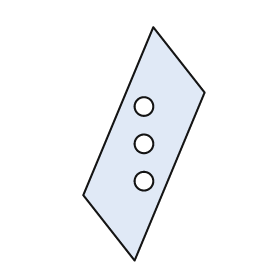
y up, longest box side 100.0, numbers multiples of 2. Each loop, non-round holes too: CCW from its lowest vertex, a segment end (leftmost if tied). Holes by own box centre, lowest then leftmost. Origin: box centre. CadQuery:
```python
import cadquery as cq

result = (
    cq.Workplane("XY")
    .moveTo(-4.0, -50.0)
    .lineTo(26.0, 22.0)
    .lineTo(4.0, 50.0)
    .lineTo(-26.0, -22.0)
    .close()
    .moveTo(0.0, -16.0)
    .circle(4.0)
    .moveTo(0.0, 0.0)
    .circle(4.0)
    .moveTo(0.0, 16.0)
    .circle(4.0)
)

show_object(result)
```